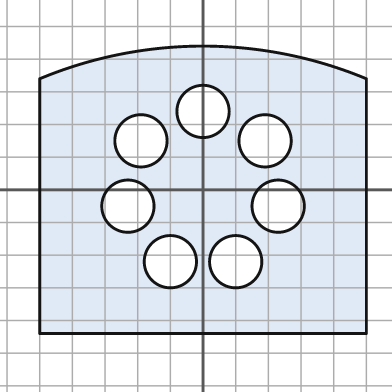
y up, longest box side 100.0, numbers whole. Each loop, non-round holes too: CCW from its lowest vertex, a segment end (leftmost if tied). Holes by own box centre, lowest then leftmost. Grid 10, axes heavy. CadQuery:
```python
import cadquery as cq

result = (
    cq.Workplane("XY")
    .moveTo(-50.0, -44.0)
    .lineTo(50.0, -44.0)
    .lineTo(50.0, 34.0)
    .threePointArc((0.0, 44.0), (-50.0, 34.0))
    .close()
    .moveTo(-10.0, -22.0)
    .circle(8.0)
    .moveTo(10.0, -22.0)
    .circle(8.0)
    .moveTo(-23.0, -5.0)
    .circle(8.0)
    .moveTo(23.0, -5.0)
    .circle(8.0)
    .moveTo(-19.0, 15.0)
    .circle(8.0)
    .moveTo(19.0, 15.0)
    .circle(8.0)
    .moveTo(0.0, 24.0)
    .circle(8.0)
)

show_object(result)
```